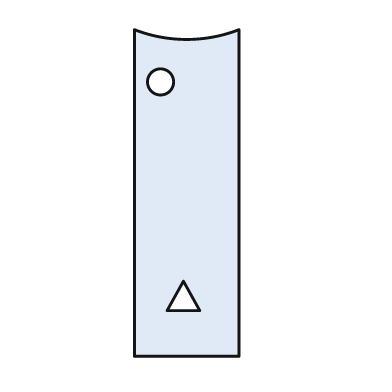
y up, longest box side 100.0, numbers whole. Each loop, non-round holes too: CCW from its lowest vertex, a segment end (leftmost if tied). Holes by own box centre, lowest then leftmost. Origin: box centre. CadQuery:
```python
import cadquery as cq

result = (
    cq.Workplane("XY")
    .moveTo(-16.0, -50.0)
    .lineTo(16.0, -50.0)
    .lineTo(16.0, 50.0)
    .threePointArc((0.0, 47.0), (-16.0, 50.0))
    .close()
    .moveTo(-6.0, -36.0)
    .lineTo(4.0, -36.0)
    .lineTo(-1.0, -27.0)
    .close()
    .moveTo(-8.0, 34.0)
    .circle(4.0)
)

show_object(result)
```